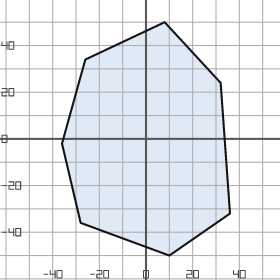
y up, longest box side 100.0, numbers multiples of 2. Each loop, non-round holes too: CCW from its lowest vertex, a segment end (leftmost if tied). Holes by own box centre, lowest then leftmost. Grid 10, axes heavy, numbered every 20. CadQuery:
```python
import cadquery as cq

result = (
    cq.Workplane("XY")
    .moveTo(10.0, -50.0)
    .lineTo(36.0, -32.0)
    .lineTo(32.0, 24.0)
    .lineTo(8.0, 50.0)
    .lineTo(-26.0, 34.0)
    .lineTo(-36.0, -2.0)
    .lineTo(-28.0, -36.0)
    .close()
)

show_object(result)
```